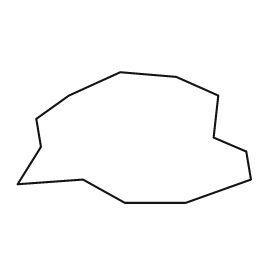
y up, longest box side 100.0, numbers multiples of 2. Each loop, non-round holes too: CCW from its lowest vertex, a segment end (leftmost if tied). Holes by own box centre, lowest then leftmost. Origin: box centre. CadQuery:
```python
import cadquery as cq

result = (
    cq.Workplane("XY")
    .moveTo(-4.0, -28.0)
    .lineTo(22.0, -28.0)
    .lineTo(50.0, -18.0)
    .lineTo(48.0, -6.0)
    .lineTo(34.0, 0.0)
    .lineTo(36.0, 18.0)
    .lineTo(18.0, 26.0)
    .lineTo(-6.0, 28.0)
    .lineTo(-28.0, 18.0)
    .lineTo(-42.0, 8.0)
    .lineTo(-40.0, -4.0)
    .lineTo(-50.0, -20.0)
    .lineTo(-22.0, -18.0)
    .close()
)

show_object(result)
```